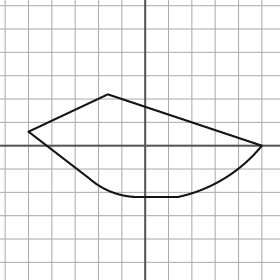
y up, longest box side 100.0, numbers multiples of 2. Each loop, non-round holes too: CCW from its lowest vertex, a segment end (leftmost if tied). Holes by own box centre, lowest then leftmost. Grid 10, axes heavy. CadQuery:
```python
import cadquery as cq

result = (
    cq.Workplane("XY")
    .moveTo(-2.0, -22.0)
    .lineTo(14.0, -22.0)
    .threePointArc((34.0, -14.0), (50.0, 0.0))
    .lineTo(-16.0, 22.0)
    .lineTo(-50.0, 6.0)
    .lineTo(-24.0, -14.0)
    .threePointArc((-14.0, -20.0), (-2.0, -22.0))
    .close()
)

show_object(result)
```